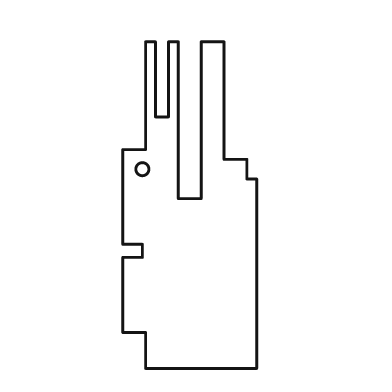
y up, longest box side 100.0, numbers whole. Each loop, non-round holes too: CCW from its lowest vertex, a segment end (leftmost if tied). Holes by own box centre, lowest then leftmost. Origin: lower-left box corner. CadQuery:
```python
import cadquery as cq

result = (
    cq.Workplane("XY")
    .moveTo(7.0, 0.0)
    .lineTo(41.0, 0.0)
    .lineTo(41.0, 58.0)
    .lineTo(38.0, 58.0)
    .lineTo(38.0, 64.0)
    .lineTo(31.0, 64.0)
    .lineTo(31.0, 100.0)
    .lineTo(24.0, 100.0)
    .lineTo(24.0, 52.0)
    .lineTo(17.0, 52.0)
    .lineTo(17.0, 100.0)
    .lineTo(14.0, 100.0)
    .lineTo(14.0, 77.0)
    .lineTo(10.0, 77.0)
    .lineTo(10.0, 100.0)
    .lineTo(7.0, 100.0)
    .lineTo(7.0, 67.0)
    .lineTo(0.0, 67.0)
    .lineTo(0.0, 38.0)
    .lineTo(6.0, 38.0)
    .lineTo(6.0, 34.0)
    .lineTo(0.0, 34.0)
    .lineTo(0.0, 11.0)
    .lineTo(7.0, 11.0)
    .close()
    .moveTo(6.0, 61.0)
    .circle(2.0)
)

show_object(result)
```